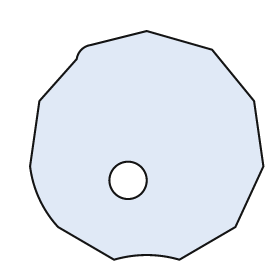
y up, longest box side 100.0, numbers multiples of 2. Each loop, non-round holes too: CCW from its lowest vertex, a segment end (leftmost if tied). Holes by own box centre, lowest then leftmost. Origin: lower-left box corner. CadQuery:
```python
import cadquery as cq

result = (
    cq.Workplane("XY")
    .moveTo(36.0, 0.0)
    .threePointArc((50.0, 2.0), (64.0, 0.0))
    .lineTo(88.0, 14.0)
    .lineTo(100.0, 40.0)
    .lineTo(96.0, 68.0)
    .lineTo(78.0, 90.0)
    .lineTo(50.0, 98.0)
    .lineTo(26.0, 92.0)
    .threePointArc((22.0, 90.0), (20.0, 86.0))
    .lineTo(4.0, 68.0)
    .lineTo(0.0, 40.0)
    .threePointArc((4.0, 26.0), (12.0, 14.0))
    .close()
    .moveTo(42.0, 34.0)
    .circle(8.0)
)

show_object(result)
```